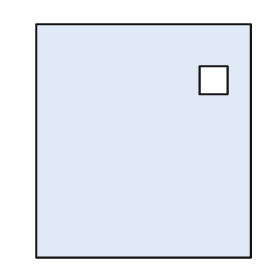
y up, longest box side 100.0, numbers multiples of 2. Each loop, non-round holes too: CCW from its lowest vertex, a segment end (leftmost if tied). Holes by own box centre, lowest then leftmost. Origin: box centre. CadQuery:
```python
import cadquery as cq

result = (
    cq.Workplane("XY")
    .moveTo(-46.0, -50.0)
    .lineTo(46.0, -50.0)
    .lineTo(46.0, 50.0)
    .lineTo(-46.0, 50.0)
    .close()
    .moveTo(24.0, 20.0)
    .lineTo(36.0, 20.0)
    .lineTo(36.0, 32.0)
    .lineTo(24.0, 32.0)
    .close()
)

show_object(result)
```